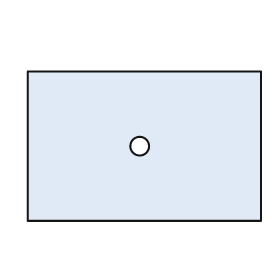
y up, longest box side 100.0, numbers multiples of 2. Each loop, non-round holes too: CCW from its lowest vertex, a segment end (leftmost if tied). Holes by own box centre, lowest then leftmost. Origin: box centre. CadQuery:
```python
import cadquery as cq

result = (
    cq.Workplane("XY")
    .moveTo(-50.0, -32.0)
    .lineTo(50.0, -32.0)
    .lineTo(50.0, 32.0)
    .lineTo(-50.0, 32.0)
    .close()
    .moveTo(-2.0, 0.0)
    .circle(4.0)
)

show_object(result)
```